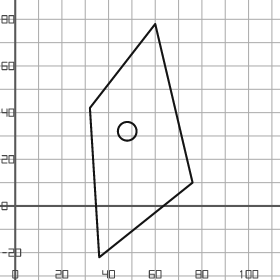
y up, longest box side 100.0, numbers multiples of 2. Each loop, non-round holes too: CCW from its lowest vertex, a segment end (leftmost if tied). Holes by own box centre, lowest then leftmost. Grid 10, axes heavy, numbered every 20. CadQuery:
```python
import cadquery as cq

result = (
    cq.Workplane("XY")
    .moveTo(36.0, -22.0)
    .lineTo(76.0, 10.0)
    .lineTo(60.0, 78.0)
    .lineTo(32.0, 42.0)
    .close()
    .moveTo(48.0, 32.0)
    .circle(4.0)
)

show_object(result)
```